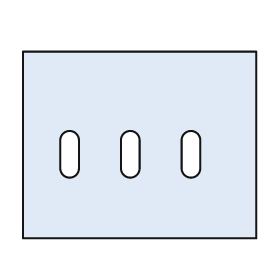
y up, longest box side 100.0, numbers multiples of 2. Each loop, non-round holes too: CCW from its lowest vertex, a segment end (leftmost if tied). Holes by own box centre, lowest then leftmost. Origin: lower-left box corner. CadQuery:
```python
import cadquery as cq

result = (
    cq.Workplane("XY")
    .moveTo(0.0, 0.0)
    .lineTo(100.0, 0.0)
    .lineTo(100.0, 80.0)
    .lineTo(0.0, 80.0)
    .close()
    .moveTo(16.0, 30.0)
    .threePointArc((20.0, 26.0), (24.0, 30.0))
    .lineTo(24.0, 42.0)
    .threePointArc((20.0, 46.0), (16.0, 42.0))
    .close()
    .moveTo(42.0, 30.0)
    .threePointArc((46.0, 26.0), (50.0, 30.0))
    .lineTo(50.0, 42.0)
    .threePointArc((46.0, 46.0), (42.0, 42.0))
    .close()
    .moveTo(68.0, 30.0)
    .threePointArc((72.0, 26.0), (76.0, 30.0))
    .lineTo(76.0, 42.0)
    .threePointArc((72.0, 46.0), (68.0, 42.0))
    .close()
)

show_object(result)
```